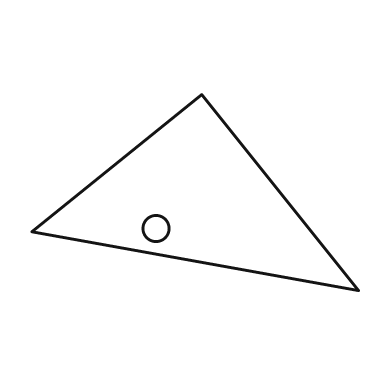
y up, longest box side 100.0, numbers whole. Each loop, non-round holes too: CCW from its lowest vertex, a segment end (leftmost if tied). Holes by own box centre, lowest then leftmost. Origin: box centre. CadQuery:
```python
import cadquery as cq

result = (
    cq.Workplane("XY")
    .moveTo(50.0, -30.0)
    .lineTo(2.0, 30.0)
    .lineTo(-50.0, -12.0)
    .close()
    .moveTo(-12.0, -11.0)
    .circle(4.0)
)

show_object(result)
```